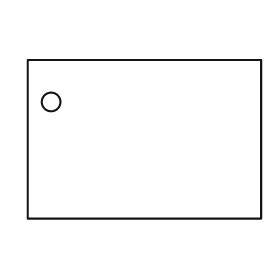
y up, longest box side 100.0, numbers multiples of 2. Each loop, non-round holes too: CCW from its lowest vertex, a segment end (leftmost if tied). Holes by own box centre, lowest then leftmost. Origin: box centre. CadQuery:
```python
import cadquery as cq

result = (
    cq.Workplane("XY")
    .moveTo(-50.0, -34.0)
    .lineTo(50.0, -34.0)
    .lineTo(50.0, 34.0)
    .lineTo(-50.0, 34.0)
    .close()
    .moveTo(-40.0, 16.0)
    .circle(4.0)
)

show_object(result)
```